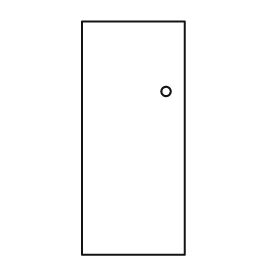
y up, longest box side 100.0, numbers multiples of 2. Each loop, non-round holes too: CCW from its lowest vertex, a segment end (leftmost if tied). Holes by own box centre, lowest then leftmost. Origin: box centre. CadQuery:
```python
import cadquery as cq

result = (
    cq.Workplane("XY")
    .moveTo(-22.0, -50.0)
    .lineTo(22.0, -50.0)
    .lineTo(22.0, 50.0)
    .lineTo(-22.0, 50.0)
    .close()
    .moveTo(14.0, 20.0)
    .circle(2.0)
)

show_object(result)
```